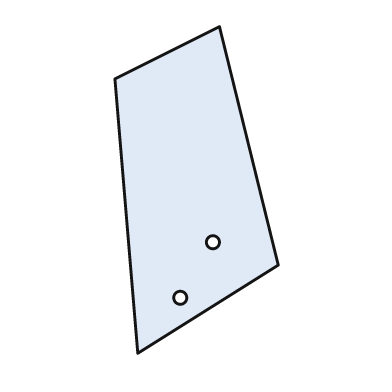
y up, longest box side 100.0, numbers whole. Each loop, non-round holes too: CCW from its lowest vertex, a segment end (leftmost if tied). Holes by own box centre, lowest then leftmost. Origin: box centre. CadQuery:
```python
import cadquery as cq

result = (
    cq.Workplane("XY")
    .moveTo(-18.0, -50.0)
    .lineTo(25.0, -23.0)
    .lineTo(7.0, 50.0)
    .lineTo(-25.0, 34.0)
    .close()
    .moveTo(-5.0, -33.0)
    .circle(2.0)
    .moveTo(5.0, -16.0)
    .circle(2.0)
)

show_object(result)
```